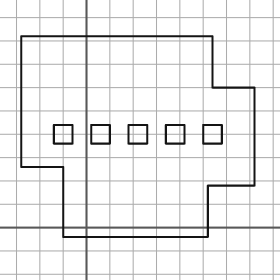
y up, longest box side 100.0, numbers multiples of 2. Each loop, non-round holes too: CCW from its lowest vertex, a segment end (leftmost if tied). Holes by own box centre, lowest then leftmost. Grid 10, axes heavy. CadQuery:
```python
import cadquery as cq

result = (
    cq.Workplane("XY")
    .moveTo(-10.0, -4.0)
    .lineTo(52.0, -4.0)
    .lineTo(52.0, 18.0)
    .lineTo(72.0, 18.0)
    .lineTo(72.0, 60.0)
    .lineTo(54.0, 60.0)
    .lineTo(54.0, 82.0)
    .lineTo(-28.0, 82.0)
    .lineTo(-28.0, 26.0)
    .lineTo(-10.0, 26.0)
    .close()
    .moveTo(-14.0, 36.0)
    .lineTo(-6.0, 36.0)
    .lineTo(-6.0, 44.0)
    .lineTo(-14.0, 44.0)
    .close()
    .moveTo(2.0, 36.0)
    .lineTo(10.0, 36.0)
    .lineTo(10.0, 44.0)
    .lineTo(2.0, 44.0)
    .close()
    .moveTo(18.0, 36.0)
    .lineTo(26.0, 36.0)
    .lineTo(26.0, 44.0)
    .lineTo(18.0, 44.0)
    .close()
    .moveTo(34.0, 36.0)
    .lineTo(42.0, 36.0)
    .lineTo(42.0, 44.0)
    .lineTo(34.0, 44.0)
    .close()
    .moveTo(50.0, 36.0)
    .lineTo(58.0, 36.0)
    .lineTo(58.0, 44.0)
    .lineTo(50.0, 44.0)
    .close()
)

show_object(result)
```